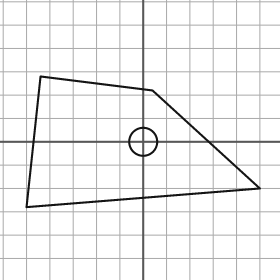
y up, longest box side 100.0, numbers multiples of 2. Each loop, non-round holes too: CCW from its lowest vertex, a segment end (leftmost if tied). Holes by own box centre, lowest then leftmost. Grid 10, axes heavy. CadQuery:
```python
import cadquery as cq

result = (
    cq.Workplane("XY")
    .moveTo(-50.0, -28.0)
    .lineTo(50.0, -20.0)
    .lineTo(4.0, 22.0)
    .lineTo(-44.0, 28.0)
    .close()
    .moveTo(0.0, 0.0)
    .circle(6.0)
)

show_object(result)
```